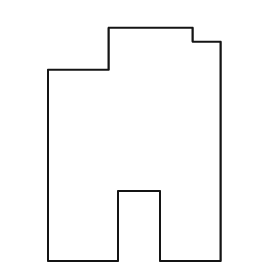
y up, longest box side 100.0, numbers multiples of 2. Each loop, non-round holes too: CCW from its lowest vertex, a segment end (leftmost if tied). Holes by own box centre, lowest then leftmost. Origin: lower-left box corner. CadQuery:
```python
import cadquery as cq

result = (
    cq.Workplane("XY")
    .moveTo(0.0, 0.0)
    .lineTo(30.0, 0.0)
    .lineTo(30.0, 30.0)
    .lineTo(48.0, 30.0)
    .lineTo(48.0, 0.0)
    .lineTo(74.0, 0.0)
    .lineTo(74.0, 94.0)
    .lineTo(62.0, 94.0)
    .lineTo(62.0, 100.0)
    .lineTo(26.0, 100.0)
    .lineTo(26.0, 82.0)
    .lineTo(0.0, 82.0)
    .close()
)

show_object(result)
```